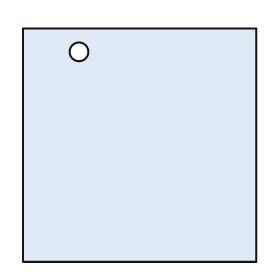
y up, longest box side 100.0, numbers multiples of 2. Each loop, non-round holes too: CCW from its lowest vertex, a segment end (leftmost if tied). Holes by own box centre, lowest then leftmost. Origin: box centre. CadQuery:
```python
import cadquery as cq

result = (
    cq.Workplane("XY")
    .moveTo(-50.0, -50.0)
    .lineTo(50.0, -50.0)
    .lineTo(50.0, 50.0)
    .lineTo(-50.0, 50.0)
    .close()
    .moveTo(-26.0, 40.0)
    .circle(4.0)
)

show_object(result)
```